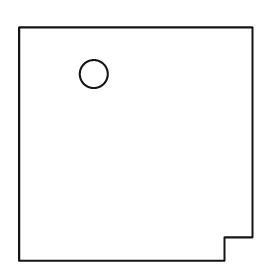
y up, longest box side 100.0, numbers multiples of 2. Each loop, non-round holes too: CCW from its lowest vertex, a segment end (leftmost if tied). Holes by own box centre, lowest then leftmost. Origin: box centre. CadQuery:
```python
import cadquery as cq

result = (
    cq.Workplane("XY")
    .moveTo(-50.0, -50.0)
    .lineTo(38.0, -50.0)
    .lineTo(38.0, -40.0)
    .lineTo(50.0, -40.0)
    .lineTo(50.0, 50.0)
    .lineTo(-50.0, 50.0)
    .close()
    .moveTo(-18.0, 30.0)
    .circle(6.0)
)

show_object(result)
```